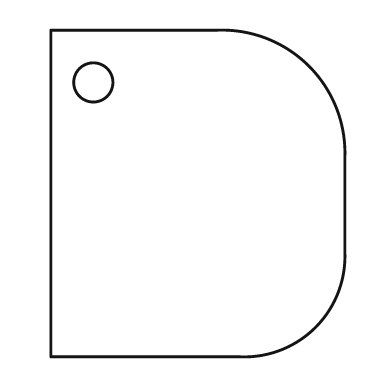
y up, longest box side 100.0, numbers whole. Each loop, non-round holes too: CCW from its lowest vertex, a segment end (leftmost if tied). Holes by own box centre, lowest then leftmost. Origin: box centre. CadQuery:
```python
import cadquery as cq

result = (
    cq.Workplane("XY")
    .moveTo(-45.0, -50.0)
    .lineTo(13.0, -50.0)
    .threePointArc((36.0, -41.0), (45.0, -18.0))
    .lineTo(45.0, 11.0)
    .threePointArc((34.0, 39.0), (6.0, 50.0))
    .lineTo(-45.0, 50.0)
    .close()
    .moveTo(-32.0, 34.0)
    .circle(6.0)
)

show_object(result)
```